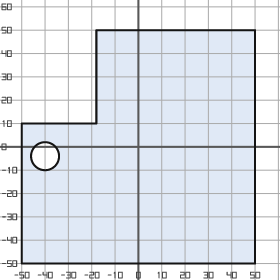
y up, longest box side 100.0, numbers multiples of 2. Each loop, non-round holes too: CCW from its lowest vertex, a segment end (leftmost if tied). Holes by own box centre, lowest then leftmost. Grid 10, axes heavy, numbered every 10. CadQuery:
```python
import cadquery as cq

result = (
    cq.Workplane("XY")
    .moveTo(-50.0, -50.0)
    .lineTo(50.0, -50.0)
    .lineTo(50.0, 50.0)
    .lineTo(-18.0, 50.0)
    .lineTo(-18.0, 10.0)
    .lineTo(-50.0, 10.0)
    .close()
    .moveTo(-40.0, -4.0)
    .circle(6.0)
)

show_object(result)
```